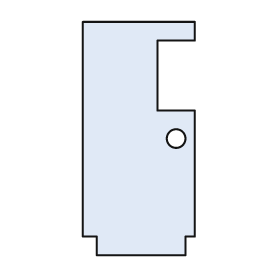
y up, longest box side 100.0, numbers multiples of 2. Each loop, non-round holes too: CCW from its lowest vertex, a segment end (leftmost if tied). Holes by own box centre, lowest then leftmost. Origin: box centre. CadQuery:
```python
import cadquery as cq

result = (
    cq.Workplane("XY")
    .moveTo(-18.0, -50.0)
    .lineTo(20.0, -50.0)
    .lineTo(20.0, -42.0)
    .lineTo(24.0, -42.0)
    .lineTo(24.0, 12.0)
    .lineTo(8.0, 12.0)
    .lineTo(8.0, 42.0)
    .lineTo(24.0, 42.0)
    .lineTo(24.0, 50.0)
    .lineTo(-24.0, 50.0)
    .lineTo(-24.0, -42.0)
    .lineTo(-18.0, -42.0)
    .close()
    .moveTo(16.0, 0.0)
    .circle(4.0)
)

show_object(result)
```